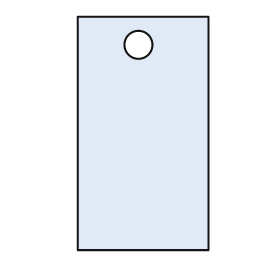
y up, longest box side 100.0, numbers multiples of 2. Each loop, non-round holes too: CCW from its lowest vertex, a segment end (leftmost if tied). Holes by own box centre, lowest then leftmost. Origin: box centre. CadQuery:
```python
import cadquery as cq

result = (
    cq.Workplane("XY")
    .moveTo(-28.0, -50.0)
    .lineTo(28.0, -50.0)
    .lineTo(28.0, 50.0)
    .lineTo(-28.0, 50.0)
    .close()
    .moveTo(-2.0, 38.0)
    .circle(6.0)
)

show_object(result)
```